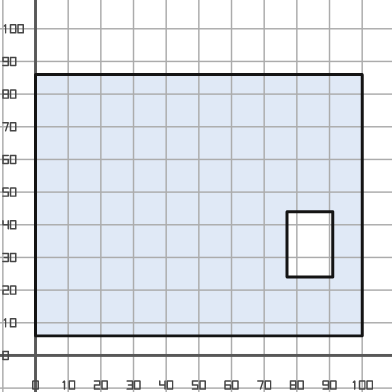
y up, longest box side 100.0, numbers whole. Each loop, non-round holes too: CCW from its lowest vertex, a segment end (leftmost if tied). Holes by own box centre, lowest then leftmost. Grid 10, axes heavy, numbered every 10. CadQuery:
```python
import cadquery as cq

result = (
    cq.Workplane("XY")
    .moveTo(0.0, 6.0)
    .lineTo(100.0, 6.0)
    .lineTo(100.0, 86.0)
    .lineTo(0.0, 86.0)
    .close()
    .moveTo(77.0, 24.0)
    .lineTo(91.0, 24.0)
    .lineTo(91.0, 44.0)
    .lineTo(77.0, 44.0)
    .close()
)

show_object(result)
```